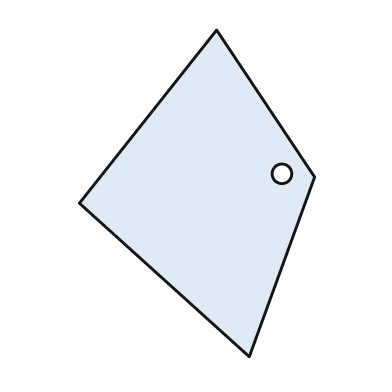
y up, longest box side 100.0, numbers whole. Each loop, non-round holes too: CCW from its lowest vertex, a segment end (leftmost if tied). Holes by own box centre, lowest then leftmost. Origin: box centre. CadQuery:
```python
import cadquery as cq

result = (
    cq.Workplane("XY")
    .moveTo(16.0, -50.0)
    .lineTo(36.0, 5.0)
    .lineTo(6.0, 50.0)
    .lineTo(-36.0, -3.0)
    .close()
    .moveTo(26.0, 6.0)
    .circle(3.0)
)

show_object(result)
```